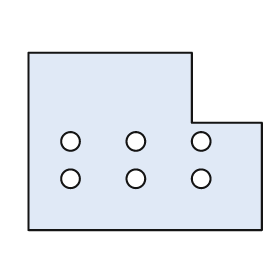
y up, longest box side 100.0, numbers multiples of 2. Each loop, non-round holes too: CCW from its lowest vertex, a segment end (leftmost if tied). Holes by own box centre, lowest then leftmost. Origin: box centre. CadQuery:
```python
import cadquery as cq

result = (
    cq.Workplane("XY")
    .moveTo(-50.0, -38.0)
    .lineTo(50.0, -38.0)
    .lineTo(50.0, 8.0)
    .lineTo(20.0, 8.0)
    .lineTo(20.0, 38.0)
    .lineTo(-50.0, 38.0)
    .close()
    .moveTo(-32.0, -16.0)
    .circle(4.0)
    .moveTo(-4.0, -16.0)
    .circle(4.0)
    .moveTo(24.0, -16.0)
    .circle(4.0)
    .moveTo(-32.0, 0.0)
    .circle(4.0)
    .moveTo(-4.0, 0.0)
    .circle(4.0)
    .moveTo(24.0, 0.0)
    .circle(4.0)
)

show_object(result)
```